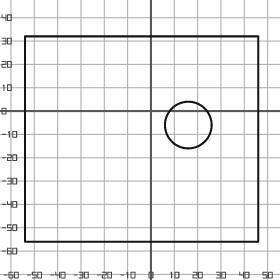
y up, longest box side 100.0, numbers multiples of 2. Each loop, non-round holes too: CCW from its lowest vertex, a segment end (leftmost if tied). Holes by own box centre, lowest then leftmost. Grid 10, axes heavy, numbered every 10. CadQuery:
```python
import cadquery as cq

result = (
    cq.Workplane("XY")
    .moveTo(-54.0, -56.0)
    .lineTo(46.0, -56.0)
    .lineTo(46.0, 32.0)
    .lineTo(-54.0, 32.0)
    .close()
    .moveTo(16.0, -6.0)
    .circle(10.0)
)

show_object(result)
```